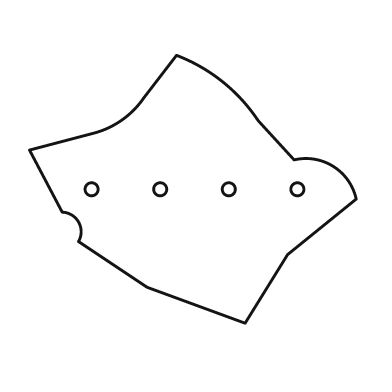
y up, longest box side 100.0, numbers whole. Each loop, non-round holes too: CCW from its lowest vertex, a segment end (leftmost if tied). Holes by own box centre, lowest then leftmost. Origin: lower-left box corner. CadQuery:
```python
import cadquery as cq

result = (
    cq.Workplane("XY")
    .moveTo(66.0, 0.0)
    .lineTo(79.0, 21.0)
    .lineTo(100.0, 38.0)
    .threePointArc((93.0, 48.0), (81.0, 50.0))
    .lineTo(70.0, 62.0)
    .threePointArc((59.0, 74.0), (45.0, 82.0))
    .lineTo(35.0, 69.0)
    .threePointArc((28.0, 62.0), (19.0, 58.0))
    .lineTo(0.0, 53.0)
    .lineTo(10.0, 34.0)
    .threePointArc((15.0, 31.0), (15.0, 25.0))
    .lineTo(36.0, 11.0)
    .close()
    .moveTo(19.0, 41.0)
    .circle(2.0)
    .moveTo(40.0, 41.0)
    .circle(2.0)
    .moveTo(61.0, 41.0)
    .circle(2.0)
    .moveTo(82.0, 41.0)
    .circle(2.0)
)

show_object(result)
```